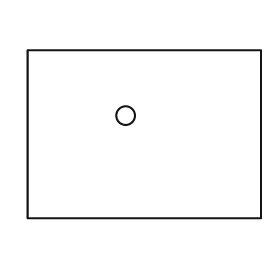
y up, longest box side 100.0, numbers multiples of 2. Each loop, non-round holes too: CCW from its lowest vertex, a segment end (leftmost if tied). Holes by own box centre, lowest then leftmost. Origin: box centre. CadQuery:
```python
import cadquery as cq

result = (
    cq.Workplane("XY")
    .moveTo(-50.0, -36.0)
    .lineTo(50.0, -36.0)
    .lineTo(50.0, 36.0)
    .lineTo(-50.0, 36.0)
    .close()
    .moveTo(-8.0, 8.0)
    .circle(4.0)
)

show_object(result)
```